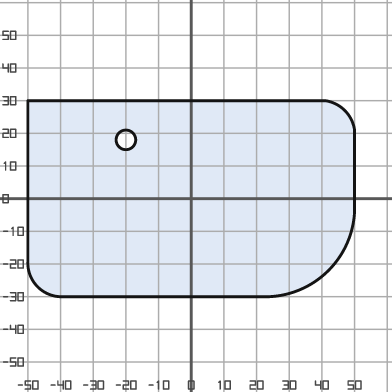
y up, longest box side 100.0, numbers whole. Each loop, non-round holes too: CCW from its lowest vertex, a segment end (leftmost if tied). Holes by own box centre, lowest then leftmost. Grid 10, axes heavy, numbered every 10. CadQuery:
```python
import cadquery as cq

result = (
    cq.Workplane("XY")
    .moveTo(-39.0, -30.0)
    .lineTo(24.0, -30.0)
    .threePointArc((42.0, -22.0), (50.0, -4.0))
    .lineTo(50.0, 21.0)
    .threePointArc((47.0, 27.0), (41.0, 30.0))
    .lineTo(-50.0, 30.0)
    .lineTo(-50.0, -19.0)
    .threePointArc((-47.0, -27.0), (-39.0, -30.0))
    .close()
    .moveTo(-20.0, 18.0)
    .circle(3.0)
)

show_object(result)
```